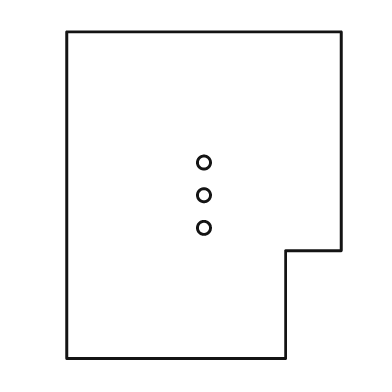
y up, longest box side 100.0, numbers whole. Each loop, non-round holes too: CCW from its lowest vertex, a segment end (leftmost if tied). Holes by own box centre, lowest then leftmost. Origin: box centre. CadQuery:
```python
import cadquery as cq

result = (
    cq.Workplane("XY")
    .moveTo(-42.0, -50.0)
    .lineTo(25.0, -50.0)
    .lineTo(25.0, -17.0)
    .lineTo(42.0, -17.0)
    .lineTo(42.0, 50.0)
    .lineTo(-42.0, 50.0)
    .close()
    .moveTo(0.0, -10.0)
    .circle(2.0)
    .moveTo(0.0, 0.0)
    .circle(2.0)
    .moveTo(0.0, 10.0)
    .circle(2.0)
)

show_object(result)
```